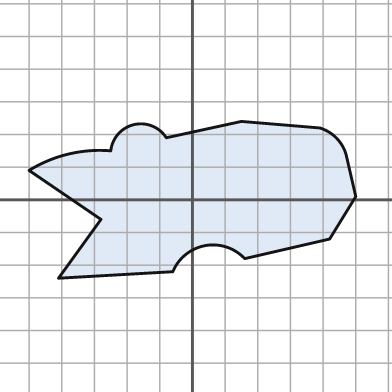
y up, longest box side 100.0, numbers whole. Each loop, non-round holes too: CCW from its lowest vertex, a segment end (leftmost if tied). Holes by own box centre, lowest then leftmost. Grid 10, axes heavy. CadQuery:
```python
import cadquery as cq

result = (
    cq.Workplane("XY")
    .moveTo(-41.0, -24.0)
    .lineTo(-6.0, -22.0)
    .threePointArc((4.0, -14.0), (16.0, -18.0))
    .lineTo(42.0, -12.0)
    .lineTo(50.0, 1.0)
    .lineTo(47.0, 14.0)
    .threePointArc((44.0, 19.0), (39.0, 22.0))
    .lineTo(15.0, 24.0)
    .lineTo(-8.0, 19.0)
    .threePointArc((-18.0, 23.0), (-25.0, 15.0))
    .threePointArc((-38.0, 14.0), (-50.0, 9.0))
    .lineTo(-28.0, -6.0)
    .close()
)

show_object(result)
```